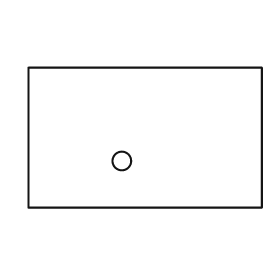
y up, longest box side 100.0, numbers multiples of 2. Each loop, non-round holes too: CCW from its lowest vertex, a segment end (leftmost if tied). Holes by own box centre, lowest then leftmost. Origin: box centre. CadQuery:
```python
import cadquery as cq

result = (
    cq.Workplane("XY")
    .moveTo(-50.0, -30.0)
    .lineTo(50.0, -30.0)
    .lineTo(50.0, 30.0)
    .lineTo(-50.0, 30.0)
    .close()
    .moveTo(-10.0, -10.0)
    .circle(4.0)
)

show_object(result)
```